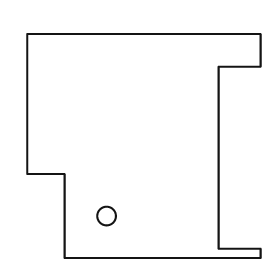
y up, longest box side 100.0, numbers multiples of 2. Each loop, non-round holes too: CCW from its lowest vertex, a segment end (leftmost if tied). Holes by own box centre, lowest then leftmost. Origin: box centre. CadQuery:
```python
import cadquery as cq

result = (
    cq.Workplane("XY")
    .moveTo(-34.0, -48.0)
    .lineTo(50.0, -48.0)
    .lineTo(50.0, -44.0)
    .lineTo(32.0, -44.0)
    .lineTo(32.0, 34.0)
    .lineTo(50.0, 34.0)
    .lineTo(50.0, 48.0)
    .lineTo(-50.0, 48.0)
    .lineTo(-50.0, -12.0)
    .lineTo(-34.0, -12.0)
    .close()
    .moveTo(-16.0, -30.0)
    .circle(4.0)
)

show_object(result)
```